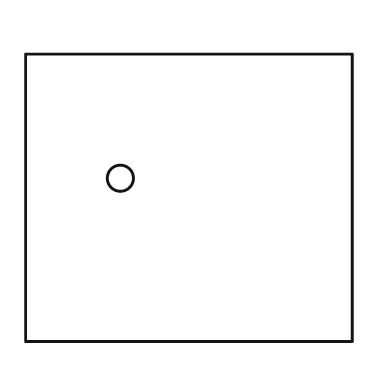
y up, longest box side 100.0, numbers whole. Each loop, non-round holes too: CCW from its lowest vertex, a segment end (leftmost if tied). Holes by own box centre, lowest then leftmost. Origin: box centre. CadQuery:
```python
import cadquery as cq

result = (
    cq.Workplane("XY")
    .moveTo(-50.0, -44.0)
    .lineTo(50.0, -44.0)
    .lineTo(50.0, 44.0)
    .lineTo(-50.0, 44.0)
    .close()
    .moveTo(-21.0, 6.0)
    .circle(4.0)
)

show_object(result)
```